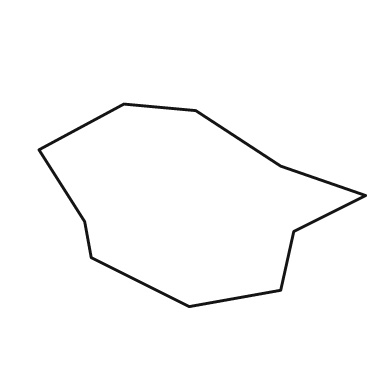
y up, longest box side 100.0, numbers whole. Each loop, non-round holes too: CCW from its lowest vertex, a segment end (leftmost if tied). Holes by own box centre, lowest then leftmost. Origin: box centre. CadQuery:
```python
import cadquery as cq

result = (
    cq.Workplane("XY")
    .moveTo(-4.0, -31.0)
    .lineTo(24.0, -26.0)
    .lineTo(28.0, -8.0)
    .lineTo(50.0, 3.0)
    .lineTo(24.0, 12.0)
    .lineTo(-2.0, 29.0)
    .lineTo(-24.0, 31.0)
    .lineTo(-50.0, 17.0)
    .lineTo(-36.0, -5.0)
    .lineTo(-34.0, -16.0)
    .close()
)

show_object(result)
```